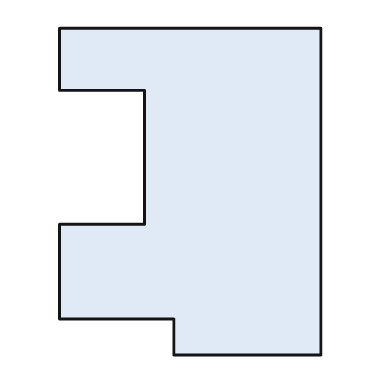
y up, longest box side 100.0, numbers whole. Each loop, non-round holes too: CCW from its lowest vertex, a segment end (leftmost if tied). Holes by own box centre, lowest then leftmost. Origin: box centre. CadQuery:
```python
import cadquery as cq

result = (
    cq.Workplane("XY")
    .moveTo(-5.0, -50.0)
    .lineTo(40.0, -50.0)
    .lineTo(40.0, 50.0)
    .lineTo(-40.0, 50.0)
    .lineTo(-40.0, 31.0)
    .lineTo(-14.0, 31.0)
    .lineTo(-14.0, -10.0)
    .lineTo(-40.0, -10.0)
    .lineTo(-40.0, -39.0)
    .lineTo(-5.0, -39.0)
    .close()
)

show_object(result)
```